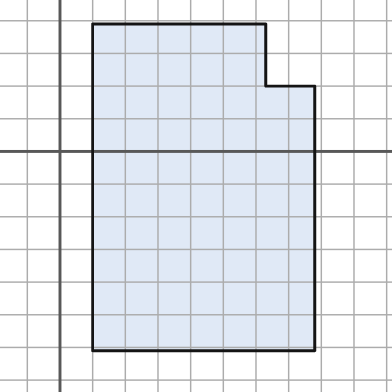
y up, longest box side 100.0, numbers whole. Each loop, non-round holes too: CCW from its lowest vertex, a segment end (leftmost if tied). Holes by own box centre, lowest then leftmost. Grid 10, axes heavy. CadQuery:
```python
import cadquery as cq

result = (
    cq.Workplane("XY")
    .moveTo(10.0, -61.0)
    .lineTo(78.0, -61.0)
    .lineTo(78.0, 20.0)
    .lineTo(63.0, 20.0)
    .lineTo(63.0, 39.0)
    .lineTo(10.0, 39.0)
    .close()
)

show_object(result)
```